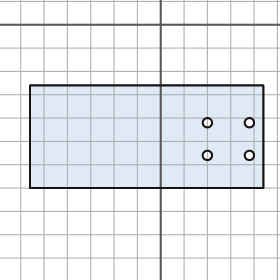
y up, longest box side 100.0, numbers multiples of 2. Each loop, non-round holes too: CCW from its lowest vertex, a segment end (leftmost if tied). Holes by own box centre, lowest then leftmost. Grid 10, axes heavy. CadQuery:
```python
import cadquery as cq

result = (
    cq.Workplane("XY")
    .moveTo(-56.0, -70.0)
    .lineTo(44.0, -70.0)
    .lineTo(44.0, -26.0)
    .lineTo(-56.0, -26.0)
    .close()
    .moveTo(20.0, -56.0)
    .circle(2.0)
    .moveTo(38.0, -56.0)
    .circle(2.0)
    .moveTo(20.0, -42.0)
    .circle(2.0)
    .moveTo(38.0, -42.0)
    .circle(2.0)
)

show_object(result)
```